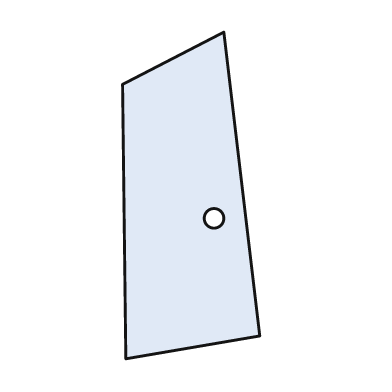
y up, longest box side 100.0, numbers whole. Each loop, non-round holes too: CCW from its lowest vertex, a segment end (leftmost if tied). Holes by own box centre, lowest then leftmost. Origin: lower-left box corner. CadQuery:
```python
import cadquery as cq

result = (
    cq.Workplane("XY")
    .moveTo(1.0, 0.0)
    .lineTo(42.0, 7.0)
    .lineTo(31.0, 100.0)
    .lineTo(0.0, 84.0)
    .close()
    .moveTo(28.0, 43.0)
    .circle(3.0)
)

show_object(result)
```